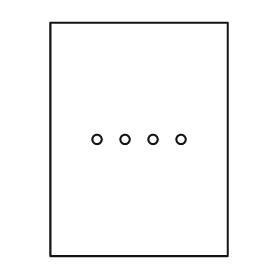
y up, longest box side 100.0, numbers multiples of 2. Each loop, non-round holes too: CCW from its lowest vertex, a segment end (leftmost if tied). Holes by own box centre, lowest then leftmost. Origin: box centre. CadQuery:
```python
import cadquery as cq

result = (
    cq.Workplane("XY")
    .moveTo(-38.0, -50.0)
    .lineTo(38.0, -50.0)
    .lineTo(38.0, 50.0)
    .lineTo(-38.0, 50.0)
    .close()
    .moveTo(-18.0, 0.0)
    .circle(2.0)
    .moveTo(-6.0, 0.0)
    .circle(2.0)
    .moveTo(6.0, 0.0)
    .circle(2.0)
    .moveTo(18.0, 0.0)
    .circle(2.0)
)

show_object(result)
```